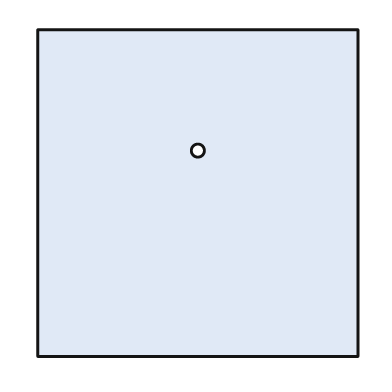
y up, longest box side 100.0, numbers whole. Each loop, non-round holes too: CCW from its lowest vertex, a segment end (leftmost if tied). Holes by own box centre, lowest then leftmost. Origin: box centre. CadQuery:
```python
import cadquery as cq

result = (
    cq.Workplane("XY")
    .moveTo(-49.0, -50.0)
    .lineTo(49.0, -50.0)
    .lineTo(49.0, 50.0)
    .lineTo(-49.0, 50.0)
    .close()
    .moveTo(0.0, 13.0)
    .circle(2.0)
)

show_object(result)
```